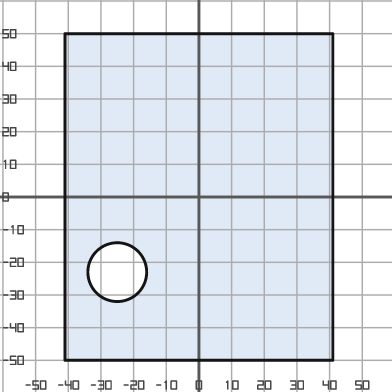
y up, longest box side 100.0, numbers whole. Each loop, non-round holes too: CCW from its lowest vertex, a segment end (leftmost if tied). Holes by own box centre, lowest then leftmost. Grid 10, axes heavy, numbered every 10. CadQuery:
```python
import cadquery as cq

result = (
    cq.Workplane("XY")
    .moveTo(-41.0, -50.0)
    .lineTo(41.0, -50.0)
    .lineTo(41.0, 50.0)
    .lineTo(-41.0, 50.0)
    .close()
    .moveTo(-25.0, -23.0)
    .circle(9.0)
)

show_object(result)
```